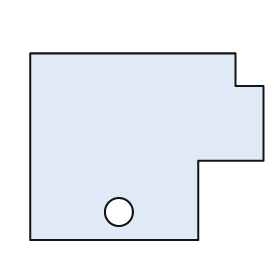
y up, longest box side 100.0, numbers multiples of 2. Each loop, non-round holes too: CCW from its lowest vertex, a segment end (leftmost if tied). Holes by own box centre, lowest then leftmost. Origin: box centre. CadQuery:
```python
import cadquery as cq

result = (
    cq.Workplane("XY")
    .moveTo(-50.0, -40.0)
    .lineTo(22.0, -40.0)
    .lineTo(22.0, -6.0)
    .lineTo(50.0, -6.0)
    .lineTo(50.0, 26.0)
    .lineTo(38.0, 26.0)
    .lineTo(38.0, 40.0)
    .lineTo(-50.0, 40.0)
    .close()
    .moveTo(-12.0, -28.0)
    .circle(6.0)
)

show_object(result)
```